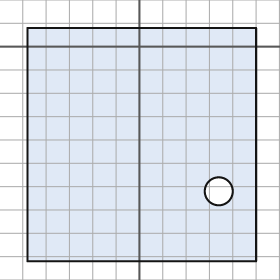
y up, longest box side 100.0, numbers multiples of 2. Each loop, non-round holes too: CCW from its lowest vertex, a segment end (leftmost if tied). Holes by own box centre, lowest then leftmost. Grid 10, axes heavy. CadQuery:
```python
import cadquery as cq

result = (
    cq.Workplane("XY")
    .moveTo(-48.0, -92.0)
    .lineTo(50.0, -92.0)
    .lineTo(50.0, 8.0)
    .lineTo(-48.0, 8.0)
    .close()
    .moveTo(34.0, -62.0)
    .circle(6.0)
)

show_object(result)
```